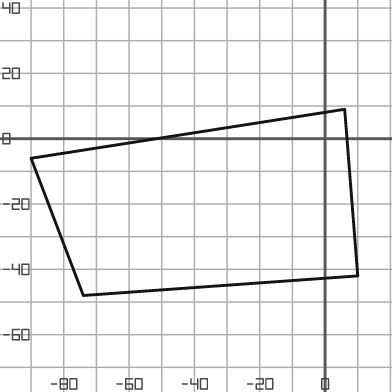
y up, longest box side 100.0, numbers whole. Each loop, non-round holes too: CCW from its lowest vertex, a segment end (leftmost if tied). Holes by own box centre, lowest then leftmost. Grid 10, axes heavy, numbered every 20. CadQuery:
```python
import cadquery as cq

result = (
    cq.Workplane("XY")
    .moveTo(-74.0, -48.0)
    .lineTo(10.0, -42.0)
    .lineTo(6.0, 9.0)
    .lineTo(-90.0, -6.0)
    .close()
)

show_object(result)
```